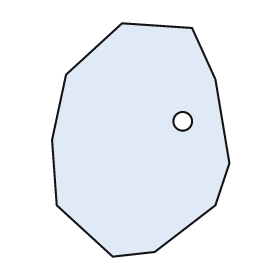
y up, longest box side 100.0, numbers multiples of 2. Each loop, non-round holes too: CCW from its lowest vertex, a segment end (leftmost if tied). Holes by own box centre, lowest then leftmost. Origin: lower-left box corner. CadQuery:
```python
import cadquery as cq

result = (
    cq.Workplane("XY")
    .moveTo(26.0, 0.0)
    .lineTo(44.0, 2.0)
    .lineTo(70.0, 22.0)
    .lineTo(76.0, 40.0)
    .lineTo(70.0, 76.0)
    .lineTo(60.0, 98.0)
    .lineTo(30.0, 100.0)
    .lineTo(6.0, 78.0)
    .lineTo(0.0, 50.0)
    .lineTo(2.0, 22.0)
    .close()
    .moveTo(56.0, 58.0)
    .circle(4.0)
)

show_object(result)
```